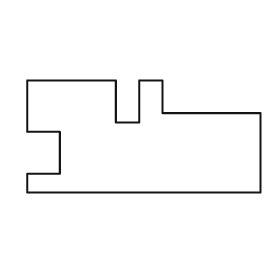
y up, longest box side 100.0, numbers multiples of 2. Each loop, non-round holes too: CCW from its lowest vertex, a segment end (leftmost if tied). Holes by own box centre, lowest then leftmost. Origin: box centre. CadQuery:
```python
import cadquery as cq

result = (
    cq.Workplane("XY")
    .moveTo(-50.0, -24.0)
    .lineTo(50.0, -24.0)
    .lineTo(50.0, 10.0)
    .lineTo(8.0, 10.0)
    .lineTo(8.0, 24.0)
    .lineTo(-2.0, 24.0)
    .lineTo(-2.0, 6.0)
    .lineTo(-12.0, 6.0)
    .lineTo(-12.0, 24.0)
    .lineTo(-50.0, 24.0)
    .lineTo(-50.0, 2.0)
    .lineTo(-36.0, 2.0)
    .lineTo(-36.0, -16.0)
    .lineTo(-50.0, -16.0)
    .close()
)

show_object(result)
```